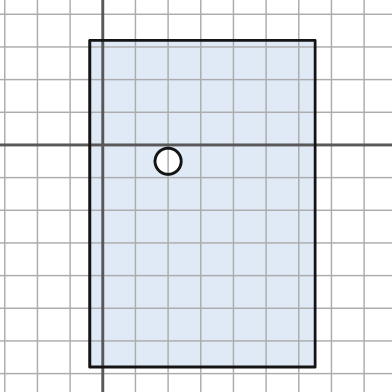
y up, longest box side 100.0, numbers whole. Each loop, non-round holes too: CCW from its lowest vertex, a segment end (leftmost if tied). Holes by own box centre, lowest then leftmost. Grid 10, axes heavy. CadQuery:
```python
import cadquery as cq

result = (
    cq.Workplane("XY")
    .moveTo(-4.0, -68.0)
    .lineTo(65.0, -68.0)
    .lineTo(65.0, 32.0)
    .lineTo(-4.0, 32.0)
    .close()
    .moveTo(20.0, -5.0)
    .circle(4.0)
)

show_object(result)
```